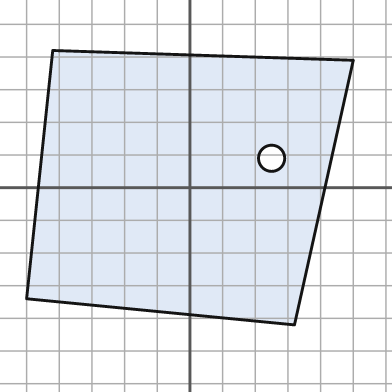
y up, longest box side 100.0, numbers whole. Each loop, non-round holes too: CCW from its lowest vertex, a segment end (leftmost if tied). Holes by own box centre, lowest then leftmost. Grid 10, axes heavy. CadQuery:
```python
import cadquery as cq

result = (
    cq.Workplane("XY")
    .moveTo(32.0, -42.0)
    .lineTo(50.0, 39.0)
    .lineTo(-42.0, 42.0)
    .lineTo(-50.0, -34.0)
    .close()
    .moveTo(25.0, 9.0)
    .circle(4.0)
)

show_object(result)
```